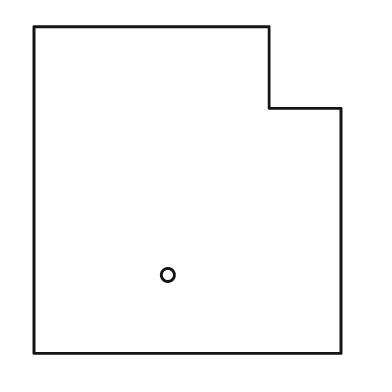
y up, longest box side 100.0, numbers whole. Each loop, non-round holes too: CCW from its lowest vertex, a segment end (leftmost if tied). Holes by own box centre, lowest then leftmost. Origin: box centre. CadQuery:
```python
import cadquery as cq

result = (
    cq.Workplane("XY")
    .moveTo(-47.0, -50.0)
    .lineTo(47.0, -50.0)
    .lineTo(47.0, 25.0)
    .lineTo(25.0, 25.0)
    .lineTo(25.0, 50.0)
    .lineTo(-47.0, 50.0)
    .close()
    .moveTo(-6.0, -26.0)
    .circle(2.0)
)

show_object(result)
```